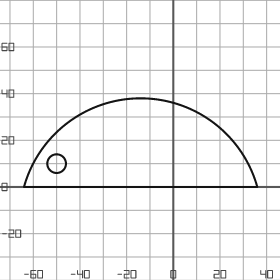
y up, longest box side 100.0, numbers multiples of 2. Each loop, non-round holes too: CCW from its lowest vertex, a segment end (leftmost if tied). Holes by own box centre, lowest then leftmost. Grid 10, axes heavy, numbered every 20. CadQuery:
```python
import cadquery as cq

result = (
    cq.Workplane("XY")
    .moveTo(-64.0, 0.0)
    .lineTo(36.0, 0.0)
    .threePointArc((-14.0, 38.0), (-64.0, 0.0))
    .close()
    .moveTo(-50.0, 10.0)
    .circle(4.0)
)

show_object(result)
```